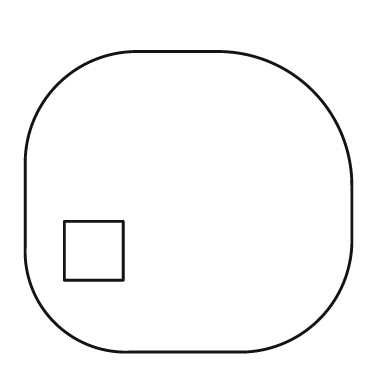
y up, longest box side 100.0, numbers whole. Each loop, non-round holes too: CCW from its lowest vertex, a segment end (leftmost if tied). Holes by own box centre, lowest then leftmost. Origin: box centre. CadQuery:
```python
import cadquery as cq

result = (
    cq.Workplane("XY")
    .moveTo(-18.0, -46.0)
    .lineTo(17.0, -46.0)
    .threePointArc((40.0, -36.0), (50.0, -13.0))
    .lineTo(50.0, 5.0)
    .threePointArc((38.0, 34.0), (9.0, 46.0))
    .lineTo(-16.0, 46.0)
    .threePointArc((-40.0, 36.0), (-50.0, 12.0))
    .lineTo(-50.0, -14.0)
    .threePointArc((-41.0, -37.0), (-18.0, -46.0))
    .close()
    .moveTo(-38.0, -24.0)
    .lineTo(-20.0, -24.0)
    .lineTo(-20.0, -6.0)
    .lineTo(-38.0, -6.0)
    .close()
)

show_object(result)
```